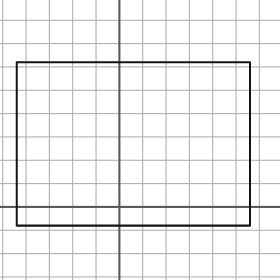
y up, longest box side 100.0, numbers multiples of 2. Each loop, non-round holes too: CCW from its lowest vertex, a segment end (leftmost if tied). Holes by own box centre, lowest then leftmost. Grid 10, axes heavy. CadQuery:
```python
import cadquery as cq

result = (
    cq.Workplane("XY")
    .moveTo(-44.0, -8.0)
    .lineTo(56.0, -8.0)
    .lineTo(56.0, 62.0)
    .lineTo(-44.0, 62.0)
    .close()
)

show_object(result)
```